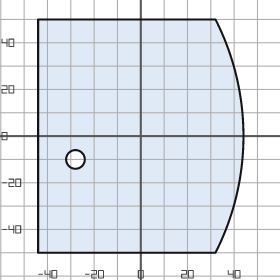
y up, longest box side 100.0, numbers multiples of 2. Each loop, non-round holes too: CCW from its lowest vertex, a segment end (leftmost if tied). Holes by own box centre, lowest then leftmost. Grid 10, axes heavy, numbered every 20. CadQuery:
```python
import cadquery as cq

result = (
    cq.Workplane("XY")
    .moveTo(-44.0, -50.0)
    .lineTo(32.0, -50.0)
    .threePointArc((44.0, 0.0), (32.0, 50.0))
    .lineTo(-44.0, 50.0)
    .close()
    .moveTo(-28.0, -10.0)
    .circle(4.0)
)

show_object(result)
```